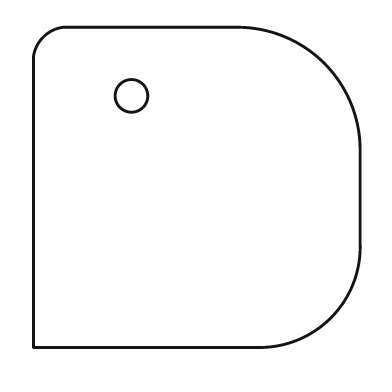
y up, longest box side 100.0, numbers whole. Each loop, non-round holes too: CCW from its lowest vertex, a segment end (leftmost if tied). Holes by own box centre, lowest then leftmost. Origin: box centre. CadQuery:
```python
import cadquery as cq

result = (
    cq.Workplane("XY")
    .moveTo(-50.0, -49.0)
    .lineTo(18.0, -49.0)
    .threePointArc((41.0, -40.0), (50.0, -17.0))
    .lineTo(50.0, 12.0)
    .threePointArc((39.0, 38.0), (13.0, 49.0))
    .lineTo(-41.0, 49.0)
    .threePointArc((-47.0, 46.0), (-50.0, 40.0))
    .close()
    .moveTo(-20.0, 28.0)
    .circle(5.0)
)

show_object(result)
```